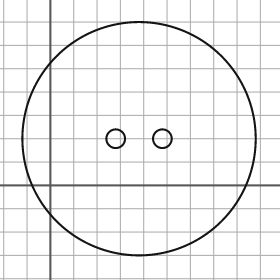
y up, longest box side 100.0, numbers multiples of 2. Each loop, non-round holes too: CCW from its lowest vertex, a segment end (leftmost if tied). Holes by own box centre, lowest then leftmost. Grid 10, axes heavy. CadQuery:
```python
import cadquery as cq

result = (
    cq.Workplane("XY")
    .moveTo(38.0, 20.0)
    .circle(50.0)
    .moveTo(28.0, 20.0)
    .circle(4.0)
    .moveTo(48.0, 20.0)
    .circle(4.0)
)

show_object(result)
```